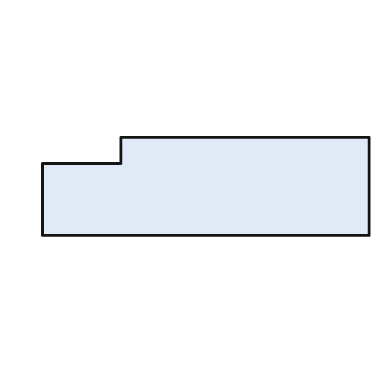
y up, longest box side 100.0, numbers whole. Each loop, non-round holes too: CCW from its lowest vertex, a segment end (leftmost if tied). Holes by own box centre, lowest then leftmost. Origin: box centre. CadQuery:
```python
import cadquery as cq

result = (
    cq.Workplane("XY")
    .moveTo(-50.0, -15.0)
    .lineTo(50.0, -15.0)
    .lineTo(50.0, 15.0)
    .lineTo(-26.0, 15.0)
    .lineTo(-26.0, 7.0)
    .lineTo(-50.0, 7.0)
    .close()
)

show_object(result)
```